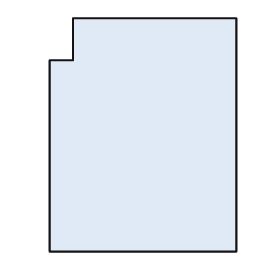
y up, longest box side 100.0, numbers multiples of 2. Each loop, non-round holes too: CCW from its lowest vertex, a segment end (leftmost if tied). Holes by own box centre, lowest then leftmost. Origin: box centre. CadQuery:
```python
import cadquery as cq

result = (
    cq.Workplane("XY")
    .moveTo(-40.0, -50.0)
    .lineTo(40.0, -50.0)
    .lineTo(40.0, 50.0)
    .lineTo(-30.0, 50.0)
    .lineTo(-30.0, 32.0)
    .lineTo(-40.0, 32.0)
    .close()
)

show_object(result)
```